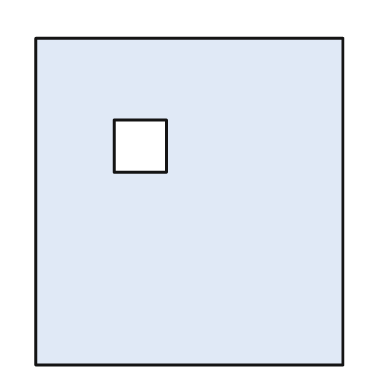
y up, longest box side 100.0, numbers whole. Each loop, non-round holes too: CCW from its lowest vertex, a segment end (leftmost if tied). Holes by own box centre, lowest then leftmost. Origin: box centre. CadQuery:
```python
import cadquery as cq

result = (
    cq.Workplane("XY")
    .moveTo(-47.0, -50.0)
    .lineTo(47.0, -50.0)
    .lineTo(47.0, 50.0)
    .lineTo(-47.0, 50.0)
    .close()
    .moveTo(-23.0, 9.0)
    .lineTo(-7.0, 9.0)
    .lineTo(-7.0, 25.0)
    .lineTo(-23.0, 25.0)
    .close()
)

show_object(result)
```